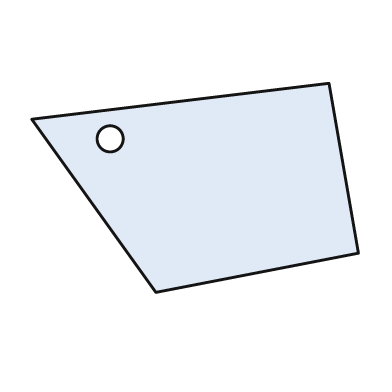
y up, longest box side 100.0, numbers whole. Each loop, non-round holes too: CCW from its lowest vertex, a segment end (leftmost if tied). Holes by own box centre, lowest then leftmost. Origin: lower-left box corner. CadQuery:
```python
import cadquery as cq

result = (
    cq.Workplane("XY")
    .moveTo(38.0, 0.0)
    .lineTo(100.0, 12.0)
    .lineTo(91.0, 64.0)
    .lineTo(0.0, 53.0)
    .close()
    .moveTo(24.0, 47.0)
    .circle(4.0)
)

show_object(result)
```